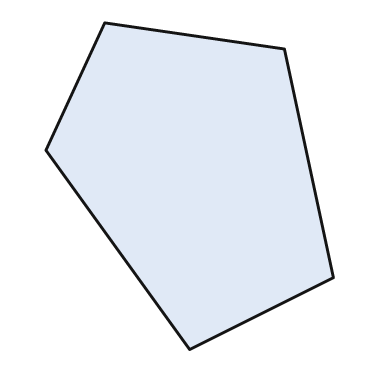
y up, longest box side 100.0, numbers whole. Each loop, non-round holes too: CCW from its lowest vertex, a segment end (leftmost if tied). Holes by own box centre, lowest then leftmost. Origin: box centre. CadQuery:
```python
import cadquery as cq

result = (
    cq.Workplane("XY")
    .moveTo(0.0, -50.0)
    .lineTo(44.0, -28.0)
    .lineTo(29.0, 42.0)
    .lineTo(-26.0, 50.0)
    .lineTo(-44.0, 11.0)
    .close()
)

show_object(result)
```